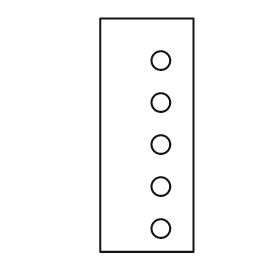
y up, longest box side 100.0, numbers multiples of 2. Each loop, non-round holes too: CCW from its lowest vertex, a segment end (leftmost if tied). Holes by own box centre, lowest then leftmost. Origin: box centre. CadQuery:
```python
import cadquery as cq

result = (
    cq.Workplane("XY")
    .moveTo(-20.0, -50.0)
    .lineTo(20.0, -50.0)
    .lineTo(20.0, 50.0)
    .lineTo(-20.0, 50.0)
    .close()
    .moveTo(6.0, -40.0)
    .circle(4.0)
    .moveTo(6.0, -22.0)
    .circle(4.0)
    .moveTo(6.0, -4.0)
    .circle(4.0)
    .moveTo(6.0, 14.0)
    .circle(4.0)
    .moveTo(6.0, 32.0)
    .circle(4.0)
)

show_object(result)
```